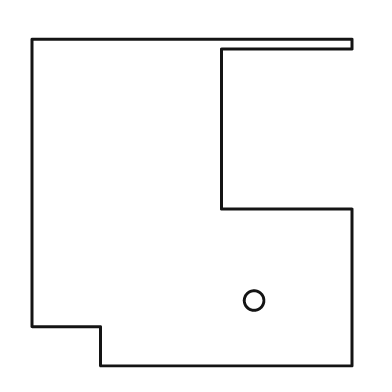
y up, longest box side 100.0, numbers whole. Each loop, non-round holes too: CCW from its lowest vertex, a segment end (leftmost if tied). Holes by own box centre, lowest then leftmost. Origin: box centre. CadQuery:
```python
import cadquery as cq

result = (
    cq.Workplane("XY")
    .moveTo(-28.0, -50.0)
    .lineTo(49.0, -50.0)
    .lineTo(49.0, -2.0)
    .lineTo(9.0, -2.0)
    .lineTo(9.0, 47.0)
    .lineTo(49.0, 47.0)
    .lineTo(49.0, 50.0)
    .lineTo(-49.0, 50.0)
    .lineTo(-49.0, -38.0)
    .lineTo(-28.0, -38.0)
    .close()
    .moveTo(19.0, -30.0)
    .circle(3.0)
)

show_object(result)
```